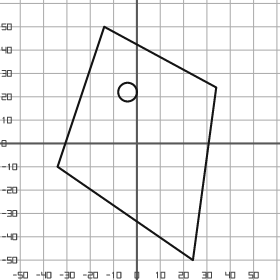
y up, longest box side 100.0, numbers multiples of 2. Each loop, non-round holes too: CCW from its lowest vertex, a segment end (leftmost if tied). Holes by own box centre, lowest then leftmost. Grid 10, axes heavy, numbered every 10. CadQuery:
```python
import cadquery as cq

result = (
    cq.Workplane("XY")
    .moveTo(24.0, -50.0)
    .lineTo(34.0, 24.0)
    .lineTo(-14.0, 50.0)
    .lineTo(-34.0, -10.0)
    .close()
    .moveTo(-4.0, 22.0)
    .circle(4.0)
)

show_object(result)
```